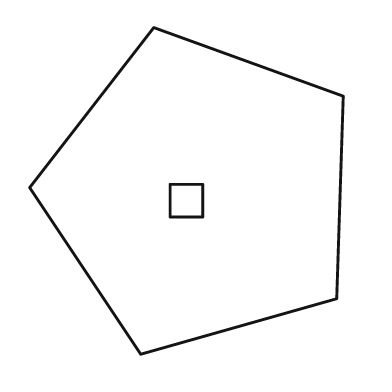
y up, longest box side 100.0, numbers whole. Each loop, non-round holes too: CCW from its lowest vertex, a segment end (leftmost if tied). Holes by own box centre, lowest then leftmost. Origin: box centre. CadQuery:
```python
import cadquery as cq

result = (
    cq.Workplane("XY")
    .moveTo(-14.0, -50.0)
    .lineTo(46.0, -33.0)
    .lineTo(48.0, 29.0)
    .lineTo(-10.0, 50.0)
    .lineTo(-48.0, 1.0)
    .close()
    .moveTo(-5.0, -8.0)
    .lineTo(5.0, -8.0)
    .lineTo(5.0, 2.0)
    .lineTo(-5.0, 2.0)
    .close()
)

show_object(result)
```